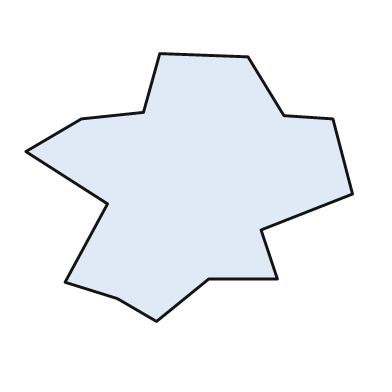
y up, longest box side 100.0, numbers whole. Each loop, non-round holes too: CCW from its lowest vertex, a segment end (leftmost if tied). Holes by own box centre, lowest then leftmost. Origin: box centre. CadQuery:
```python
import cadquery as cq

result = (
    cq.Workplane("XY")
    .moveTo(-10.0, -41.0)
    .lineTo(6.0, -28.0)
    .lineTo(27.0, -28.0)
    .lineTo(22.0, -13.0)
    .lineTo(50.0, -2.0)
    .lineTo(44.0, 21.0)
    .lineTo(29.0, 22.0)
    .lineTo(18.0, 40.0)
    .lineTo(-9.0, 41.0)
    .lineTo(-14.0, 23.0)
    .lineTo(-33.0, 21.0)
    .lineTo(-50.0, 11.0)
    .lineTo(-25.0, -5.0)
    .lineTo(-38.0, -29.0)
    .lineTo(-22.0, -34.0)
    .close()
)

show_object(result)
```